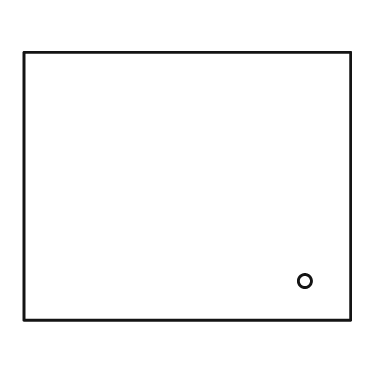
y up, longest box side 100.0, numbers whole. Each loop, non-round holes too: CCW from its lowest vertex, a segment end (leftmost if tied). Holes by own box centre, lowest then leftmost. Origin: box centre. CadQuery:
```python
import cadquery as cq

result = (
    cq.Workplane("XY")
    .moveTo(-50.0, -41.0)
    .lineTo(50.0, -41.0)
    .lineTo(50.0, 41.0)
    .lineTo(-50.0, 41.0)
    .close()
    .moveTo(36.0, -29.0)
    .circle(2.0)
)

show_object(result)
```